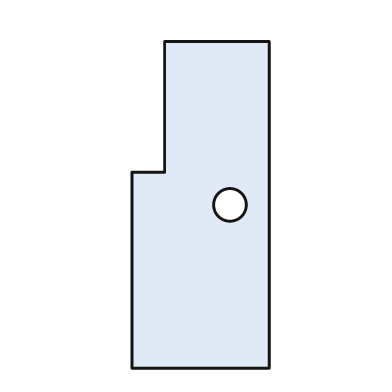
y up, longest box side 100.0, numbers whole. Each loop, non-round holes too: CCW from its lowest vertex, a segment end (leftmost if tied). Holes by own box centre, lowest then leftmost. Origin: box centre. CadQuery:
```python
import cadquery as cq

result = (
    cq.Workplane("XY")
    .moveTo(-21.0, -50.0)
    .lineTo(21.0, -50.0)
    .lineTo(21.0, 50.0)
    .lineTo(-11.0, 50.0)
    .lineTo(-11.0, 10.0)
    .lineTo(-21.0, 10.0)
    .close()
    .moveTo(9.0, 0.0)
    .circle(5.0)
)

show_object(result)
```